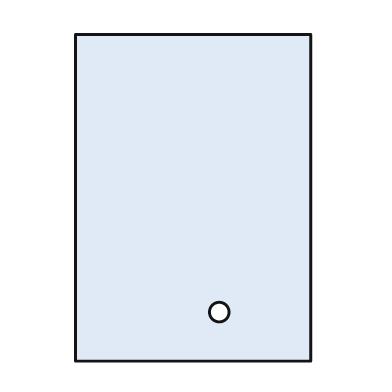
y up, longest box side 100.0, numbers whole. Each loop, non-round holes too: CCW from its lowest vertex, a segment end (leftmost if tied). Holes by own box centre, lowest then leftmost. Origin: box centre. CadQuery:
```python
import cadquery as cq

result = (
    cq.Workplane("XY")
    .moveTo(-36.0, -50.0)
    .lineTo(36.0, -50.0)
    .lineTo(36.0, 50.0)
    .lineTo(-36.0, 50.0)
    .close()
    .moveTo(8.0, -35.0)
    .circle(3.0)
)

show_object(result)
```